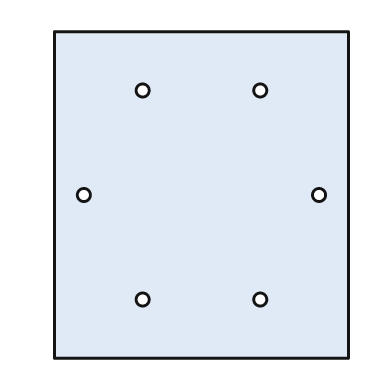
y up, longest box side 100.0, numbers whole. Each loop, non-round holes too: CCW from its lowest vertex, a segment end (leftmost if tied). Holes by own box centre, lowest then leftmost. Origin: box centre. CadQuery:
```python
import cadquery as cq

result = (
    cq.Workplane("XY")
    .moveTo(-45.0, -50.0)
    .lineTo(45.0, -50.0)
    .lineTo(45.0, 50.0)
    .lineTo(-45.0, 50.0)
    .close()
    .moveTo(-18.0, -32.0)
    .circle(2.0)
    .moveTo(18.0, -32.0)
    .circle(2.0)
    .moveTo(-36.0, 0.0)
    .circle(2.0)
    .moveTo(36.0, 0.0)
    .circle(2.0)
    .moveTo(-18.0, 32.0)
    .circle(2.0)
    .moveTo(18.0, 32.0)
    .circle(2.0)
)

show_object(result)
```